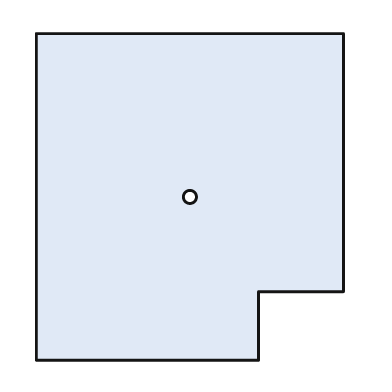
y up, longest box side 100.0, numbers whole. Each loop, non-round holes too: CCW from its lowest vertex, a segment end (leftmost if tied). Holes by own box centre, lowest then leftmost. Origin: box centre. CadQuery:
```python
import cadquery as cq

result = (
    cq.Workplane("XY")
    .moveTo(-47.0, -50.0)
    .lineTo(21.0, -50.0)
    .lineTo(21.0, -29.0)
    .lineTo(47.0, -29.0)
    .lineTo(47.0, 50.0)
    .lineTo(-47.0, 50.0)
    .close()
    .moveTo(0.0, 0.0)
    .circle(2.0)
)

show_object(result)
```